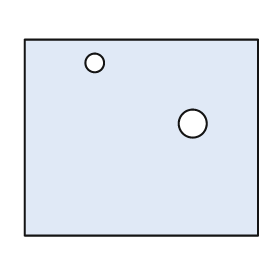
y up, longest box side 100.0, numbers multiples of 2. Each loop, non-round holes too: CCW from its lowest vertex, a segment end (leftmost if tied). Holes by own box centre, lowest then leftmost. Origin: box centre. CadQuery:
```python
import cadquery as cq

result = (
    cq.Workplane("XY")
    .moveTo(-50.0, -42.0)
    .lineTo(50.0, -42.0)
    .lineTo(50.0, 42.0)
    .lineTo(-50.0, 42.0)
    .close()
    .moveTo(22.0, 6.0)
    .circle(6.0)
    .moveTo(-20.0, 32.0)
    .circle(4.0)
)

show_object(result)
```